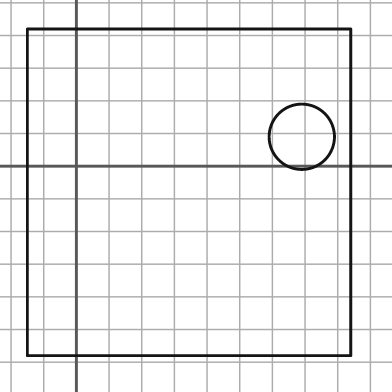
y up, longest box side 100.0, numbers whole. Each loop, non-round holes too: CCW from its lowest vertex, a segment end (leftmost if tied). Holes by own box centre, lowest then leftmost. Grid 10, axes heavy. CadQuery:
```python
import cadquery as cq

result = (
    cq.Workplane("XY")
    .moveTo(-15.0, -58.0)
    .lineTo(84.0, -58.0)
    .lineTo(84.0, 42.0)
    .lineTo(-15.0, 42.0)
    .close()
    .moveTo(69.0, 9.0)
    .circle(10.0)
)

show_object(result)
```